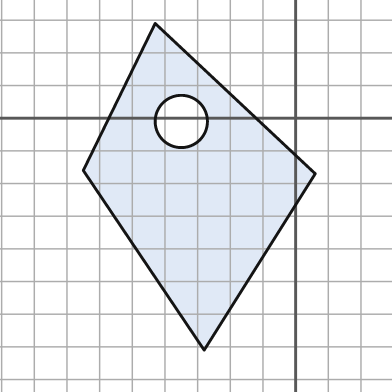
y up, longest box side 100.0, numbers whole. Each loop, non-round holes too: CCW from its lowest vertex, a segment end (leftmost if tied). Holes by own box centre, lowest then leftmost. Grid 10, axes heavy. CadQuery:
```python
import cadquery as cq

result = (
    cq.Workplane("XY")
    .moveTo(-28.0, -71.0)
    .lineTo(6.0, -17.0)
    .lineTo(-43.0, 29.0)
    .lineTo(-65.0, -16.0)
    .close()
    .moveTo(-35.0, -1.0)
    .circle(8.0)
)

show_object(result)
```